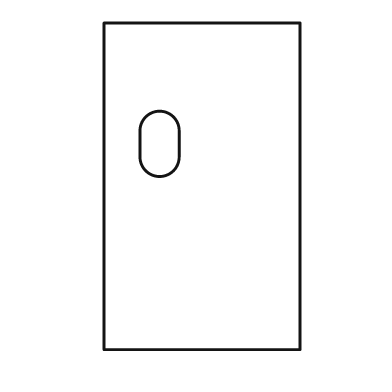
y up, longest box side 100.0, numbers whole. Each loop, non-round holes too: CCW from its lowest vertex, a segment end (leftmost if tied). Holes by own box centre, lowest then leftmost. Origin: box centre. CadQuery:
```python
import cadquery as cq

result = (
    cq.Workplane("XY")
    .moveTo(-30.0, -50.0)
    .lineTo(30.0, -50.0)
    .lineTo(30.0, 50.0)
    .lineTo(-30.0, 50.0)
    .close()
    .moveTo(-19.0, 9.0)
    .threePointArc((-13.0, 3.0), (-7.0, 9.0))
    .lineTo(-7.0, 17.0)
    .threePointArc((-13.0, 23.0), (-19.0, 17.0))
    .close()
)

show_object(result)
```